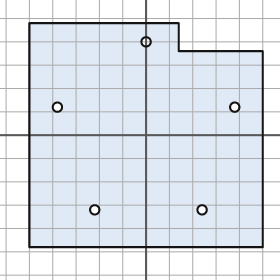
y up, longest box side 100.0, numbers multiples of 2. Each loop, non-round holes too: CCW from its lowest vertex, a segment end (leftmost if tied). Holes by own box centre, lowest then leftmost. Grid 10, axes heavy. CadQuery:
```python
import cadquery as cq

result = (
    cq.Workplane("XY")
    .moveTo(-50.0, -48.0)
    .lineTo(50.0, -48.0)
    .lineTo(50.0, 36.0)
    .lineTo(14.0, 36.0)
    .lineTo(14.0, 48.0)
    .lineTo(-50.0, 48.0)
    .close()
    .moveTo(-22.0, -32.0)
    .circle(2.0)
    .moveTo(24.0, -32.0)
    .circle(2.0)
    .moveTo(-38.0, 12.0)
    .circle(2.0)
    .moveTo(38.0, 12.0)
    .circle(2.0)
    .moveTo(0.0, 40.0)
    .circle(2.0)
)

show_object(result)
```